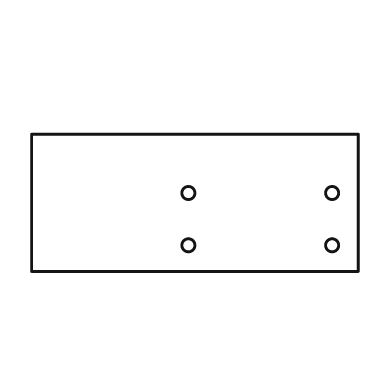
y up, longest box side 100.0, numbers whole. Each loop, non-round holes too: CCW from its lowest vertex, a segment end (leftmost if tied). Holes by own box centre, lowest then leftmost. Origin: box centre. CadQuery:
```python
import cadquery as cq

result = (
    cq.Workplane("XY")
    .moveTo(-50.0, -21.0)
    .lineTo(50.0, -21.0)
    .lineTo(50.0, 21.0)
    .lineTo(-50.0, 21.0)
    .close()
    .moveTo(-2.0, -13.0)
    .circle(2.0)
    .moveTo(42.0, -13.0)
    .circle(2.0)
    .moveTo(-2.0, 3.0)
    .circle(2.0)
    .moveTo(42.0, 3.0)
    .circle(2.0)
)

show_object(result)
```